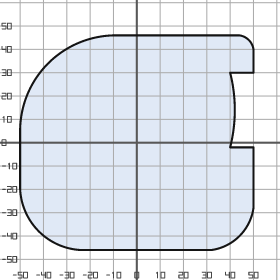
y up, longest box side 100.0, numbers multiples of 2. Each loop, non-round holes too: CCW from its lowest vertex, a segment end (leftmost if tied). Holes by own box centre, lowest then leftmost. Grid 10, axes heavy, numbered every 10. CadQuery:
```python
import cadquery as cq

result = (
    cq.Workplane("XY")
    .moveTo(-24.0, -46.0)
    .lineTo(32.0, -46.0)
    .threePointArc((44.0, -40.0), (50.0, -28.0))
    .lineTo(50.0, -2.0)
    .lineTo(40.0, -2.0)
    .threePointArc((42.0, 14.0), (40.0, 30.0))
    .lineTo(50.0, 30.0)
    .lineTo(50.0, 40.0)
    .threePointArc((48.0, 44.0), (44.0, 46.0))
    .lineTo(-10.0, 46.0)
    .threePointArc((-38.0, 34.0), (-50.0, 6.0))
    .lineTo(-50.0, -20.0)
    .threePointArc((-42.0, -38.0), (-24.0, -46.0))
    .close()
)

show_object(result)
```